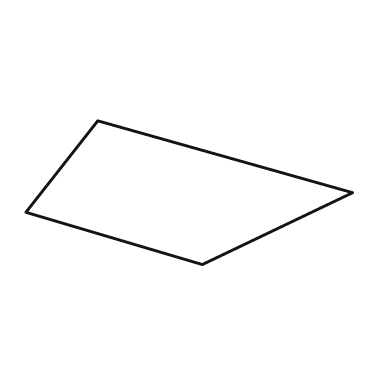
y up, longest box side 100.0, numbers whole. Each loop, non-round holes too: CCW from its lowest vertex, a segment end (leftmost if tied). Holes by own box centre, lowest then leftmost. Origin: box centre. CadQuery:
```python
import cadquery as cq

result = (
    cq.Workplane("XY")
    .moveTo(4.0, -22.0)
    .lineTo(50.0, 0.0)
    .lineTo(-28.0, 22.0)
    .lineTo(-50.0, -6.0)
    .close()
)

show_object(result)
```